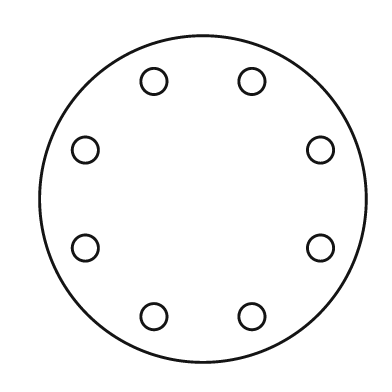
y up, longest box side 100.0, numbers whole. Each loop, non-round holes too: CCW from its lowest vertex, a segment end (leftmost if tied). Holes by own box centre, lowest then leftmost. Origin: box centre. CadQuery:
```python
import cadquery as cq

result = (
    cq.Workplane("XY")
    .moveTo(0.0, 0.0)
    .circle(50.0)
    .moveTo(-15.0, -36.0)
    .circle(4.0)
    .moveTo(15.0, -36.0)
    .circle(4.0)
    .moveTo(-36.0, -15.0)
    .circle(4.0)
    .moveTo(36.0, -15.0)
    .circle(4.0)
    .moveTo(-36.0, 15.0)
    .circle(4.0)
    .moveTo(36.0, 15.0)
    .circle(4.0)
    .moveTo(-15.0, 36.0)
    .circle(4.0)
    .moveTo(15.0, 36.0)
    .circle(4.0)
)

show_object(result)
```